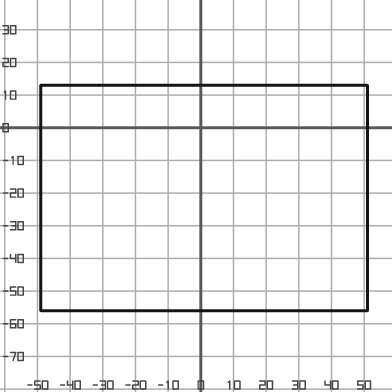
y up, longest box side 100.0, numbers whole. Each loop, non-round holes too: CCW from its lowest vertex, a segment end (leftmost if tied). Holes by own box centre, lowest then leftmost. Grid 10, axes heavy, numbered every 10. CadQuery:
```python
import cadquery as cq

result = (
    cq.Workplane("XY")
    .moveTo(-49.0, -56.0)
    .lineTo(51.0, -56.0)
    .lineTo(51.0, 13.0)
    .lineTo(-49.0, 13.0)
    .close()
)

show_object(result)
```